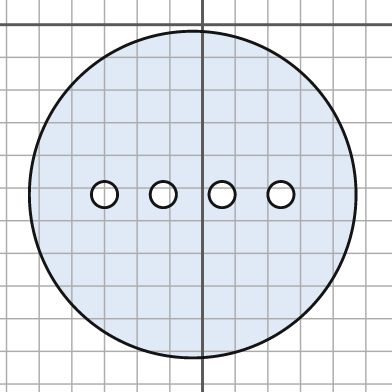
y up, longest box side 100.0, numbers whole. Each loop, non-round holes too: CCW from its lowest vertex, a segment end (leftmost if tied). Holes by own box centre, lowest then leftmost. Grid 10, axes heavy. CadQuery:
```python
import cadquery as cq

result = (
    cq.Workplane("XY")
    .moveTo(-3.0, -52.0)
    .circle(50.0)
    .moveTo(-30.0, -52.0)
    .circle(4.0)
    .moveTo(-12.0, -52.0)
    .circle(4.0)
    .moveTo(6.0, -52.0)
    .circle(4.0)
    .moveTo(24.0, -52.0)
    .circle(4.0)
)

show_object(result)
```